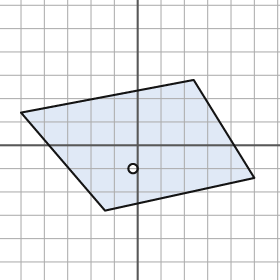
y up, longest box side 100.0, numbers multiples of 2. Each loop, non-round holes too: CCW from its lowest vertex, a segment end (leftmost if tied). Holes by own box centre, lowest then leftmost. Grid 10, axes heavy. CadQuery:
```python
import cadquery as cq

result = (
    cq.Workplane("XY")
    .moveTo(-14.0, -28.0)
    .lineTo(50.0, -14.0)
    .lineTo(24.0, 28.0)
    .lineTo(-50.0, 14.0)
    .close()
    .moveTo(-2.0, -10.0)
    .circle(2.0)
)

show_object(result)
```